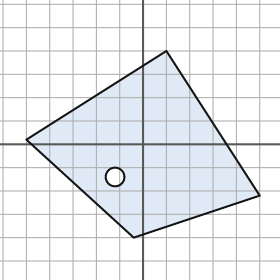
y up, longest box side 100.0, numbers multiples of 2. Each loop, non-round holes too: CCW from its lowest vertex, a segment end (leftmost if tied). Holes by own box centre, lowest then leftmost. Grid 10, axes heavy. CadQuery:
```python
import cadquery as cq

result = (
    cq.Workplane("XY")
    .moveTo(-4.0, -40.0)
    .lineTo(50.0, -22.0)
    .lineTo(10.0, 40.0)
    .lineTo(-50.0, 2.0)
    .close()
    .moveTo(-12.0, -14.0)
    .circle(4.0)
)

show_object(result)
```